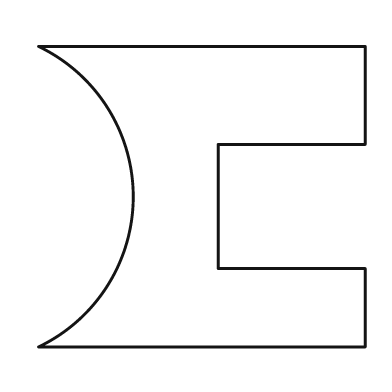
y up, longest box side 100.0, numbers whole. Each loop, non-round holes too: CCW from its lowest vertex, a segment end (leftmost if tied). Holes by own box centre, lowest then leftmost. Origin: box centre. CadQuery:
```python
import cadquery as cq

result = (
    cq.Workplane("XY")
    .moveTo(-50.0, -46.0)
    .lineTo(50.0, -46.0)
    .lineTo(50.0, -22.0)
    .lineTo(5.0, -22.0)
    .lineTo(5.0, 16.0)
    .lineTo(50.0, 16.0)
    .lineTo(50.0, 46.0)
    .lineTo(-50.0, 46.0)
    .threePointArc((-21.0, 0.0), (-50.0, -46.0))
    .close()
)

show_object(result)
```